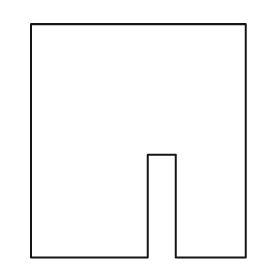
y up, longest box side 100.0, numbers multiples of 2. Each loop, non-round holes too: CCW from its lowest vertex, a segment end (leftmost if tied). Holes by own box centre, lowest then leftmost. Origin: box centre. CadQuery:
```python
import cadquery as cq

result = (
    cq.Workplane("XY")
    .moveTo(-46.0, -50.0)
    .lineTo(4.0, -50.0)
    .lineTo(4.0, -6.0)
    .lineTo(16.0, -6.0)
    .lineTo(16.0, -50.0)
    .lineTo(46.0, -50.0)
    .lineTo(46.0, 50.0)
    .lineTo(-46.0, 50.0)
    .close()
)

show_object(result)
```